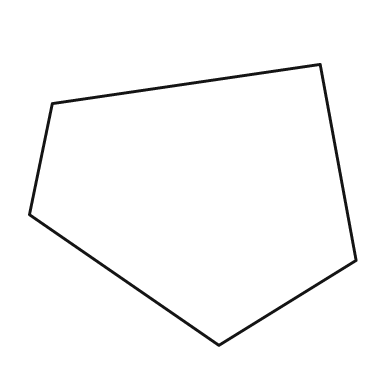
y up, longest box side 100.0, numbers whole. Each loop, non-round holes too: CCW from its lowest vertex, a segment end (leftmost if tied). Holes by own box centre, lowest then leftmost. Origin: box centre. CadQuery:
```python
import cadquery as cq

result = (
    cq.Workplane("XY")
    .moveTo(8.0, -43.0)
    .lineTo(50.0, -17.0)
    .lineTo(39.0, 43.0)
    .lineTo(-43.0, 31.0)
    .lineTo(-50.0, -3.0)
    .close()
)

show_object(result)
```